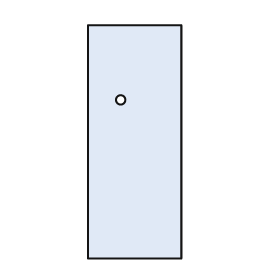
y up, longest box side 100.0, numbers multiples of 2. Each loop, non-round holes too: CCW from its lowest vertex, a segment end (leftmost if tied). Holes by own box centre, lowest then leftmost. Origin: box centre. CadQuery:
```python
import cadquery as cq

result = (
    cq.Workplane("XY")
    .moveTo(-20.0, -50.0)
    .lineTo(20.0, -50.0)
    .lineTo(20.0, 50.0)
    .lineTo(-20.0, 50.0)
    .close()
    .moveTo(-6.0, 18.0)
    .circle(2.0)
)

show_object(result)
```